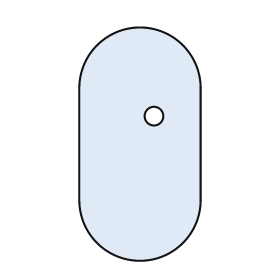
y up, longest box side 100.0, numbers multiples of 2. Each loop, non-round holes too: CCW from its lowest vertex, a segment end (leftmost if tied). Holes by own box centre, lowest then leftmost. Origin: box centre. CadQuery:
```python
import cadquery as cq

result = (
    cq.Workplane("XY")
    .moveTo(-26.0, -24.0)
    .threePointArc((0.0, -50.0), (26.0, -24.0))
    .lineTo(26.0, 24.0)
    .threePointArc((0.0, 50.0), (-26.0, 24.0))
    .close()
    .moveTo(6.0, 12.0)
    .circle(4.0)
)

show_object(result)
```